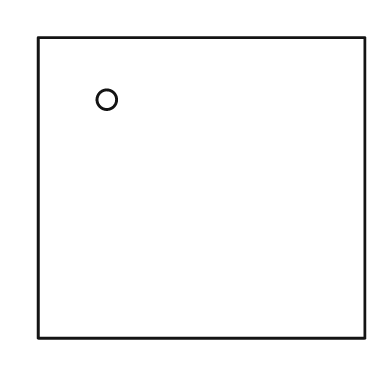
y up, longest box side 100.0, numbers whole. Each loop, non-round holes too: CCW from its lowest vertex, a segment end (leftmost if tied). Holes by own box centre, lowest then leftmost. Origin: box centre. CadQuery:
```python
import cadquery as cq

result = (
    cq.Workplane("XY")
    .moveTo(-50.0, -46.0)
    .lineTo(50.0, -46.0)
    .lineTo(50.0, 46.0)
    .lineTo(-50.0, 46.0)
    .close()
    .moveTo(-29.0, 27.0)
    .circle(3.0)
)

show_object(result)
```